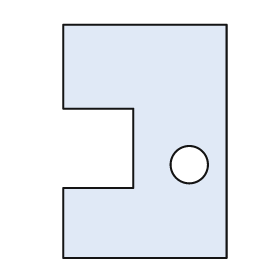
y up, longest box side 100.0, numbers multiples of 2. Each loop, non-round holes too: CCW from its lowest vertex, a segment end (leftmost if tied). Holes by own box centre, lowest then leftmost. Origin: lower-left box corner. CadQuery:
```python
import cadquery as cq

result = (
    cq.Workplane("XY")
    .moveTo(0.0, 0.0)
    .lineTo(70.0, 0.0)
    .lineTo(70.0, 100.0)
    .lineTo(0.0, 100.0)
    .lineTo(0.0, 64.0)
    .lineTo(30.0, 64.0)
    .lineTo(30.0, 30.0)
    .lineTo(0.0, 30.0)
    .close()
    .moveTo(54.0, 40.0)
    .circle(8.0)
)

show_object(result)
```